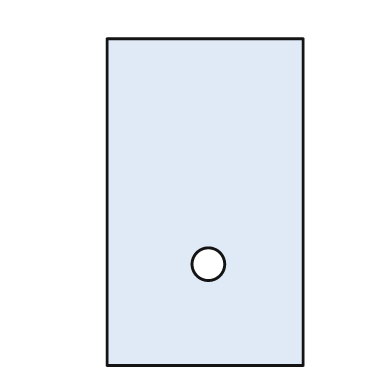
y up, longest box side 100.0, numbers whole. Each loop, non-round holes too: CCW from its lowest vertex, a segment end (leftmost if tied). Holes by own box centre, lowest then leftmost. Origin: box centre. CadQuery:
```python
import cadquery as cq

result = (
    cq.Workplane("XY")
    .moveTo(-30.0, -50.0)
    .lineTo(30.0, -50.0)
    .lineTo(30.0, 50.0)
    .lineTo(-30.0, 50.0)
    .close()
    .moveTo(1.0, -19.0)
    .circle(5.0)
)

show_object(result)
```